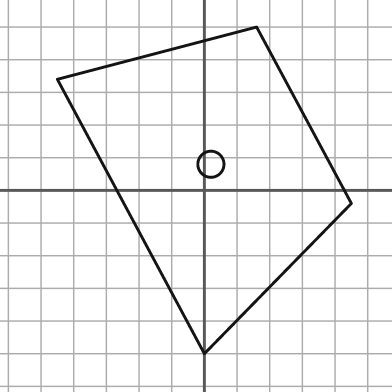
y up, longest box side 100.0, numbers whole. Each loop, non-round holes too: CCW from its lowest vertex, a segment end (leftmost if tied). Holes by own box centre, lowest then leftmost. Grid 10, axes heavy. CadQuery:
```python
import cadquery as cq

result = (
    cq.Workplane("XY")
    .moveTo(0.0, -50.0)
    .lineTo(45.0, -4.0)
    .lineTo(16.0, 50.0)
    .lineTo(-45.0, 34.0)
    .close()
    .moveTo(2.0, 8.0)
    .circle(4.0)
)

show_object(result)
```